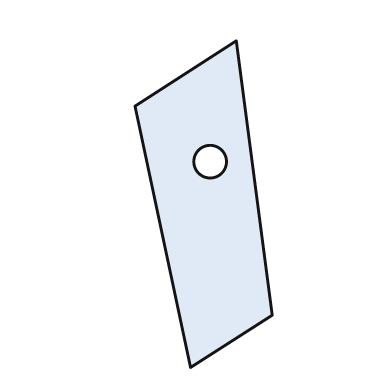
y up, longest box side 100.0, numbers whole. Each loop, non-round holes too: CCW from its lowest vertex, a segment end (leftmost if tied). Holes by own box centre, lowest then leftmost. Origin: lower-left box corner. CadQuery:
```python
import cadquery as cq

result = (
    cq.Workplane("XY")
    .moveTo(17.0, 0.0)
    .lineTo(42.0, 16.0)
    .lineTo(31.0, 100.0)
    .lineTo(0.0, 80.0)
    .close()
    .moveTo(23.0, 63.0)
    .circle(5.0)
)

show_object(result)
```